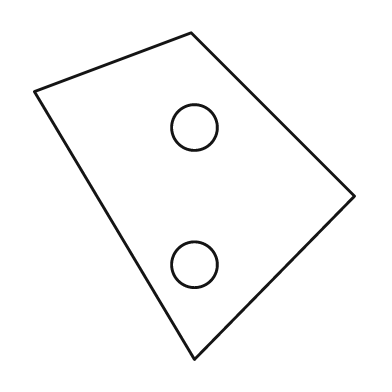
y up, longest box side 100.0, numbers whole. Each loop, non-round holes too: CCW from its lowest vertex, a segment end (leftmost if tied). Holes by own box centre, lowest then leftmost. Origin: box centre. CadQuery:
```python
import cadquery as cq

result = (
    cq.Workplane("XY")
    .moveTo(0.0, -50.0)
    .lineTo(49.0, 0.0)
    .lineTo(-1.0, 50.0)
    .lineTo(-49.0, 32.0)
    .close()
    .moveTo(0.0, -21.0)
    .circle(7.0)
    .moveTo(0.0, 21.0)
    .circle(7.0)
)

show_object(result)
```